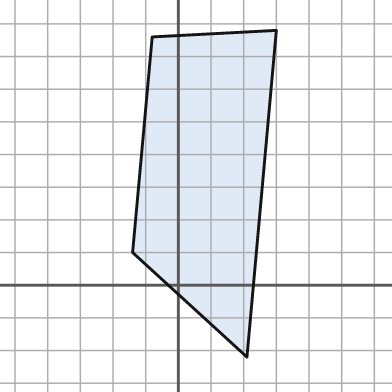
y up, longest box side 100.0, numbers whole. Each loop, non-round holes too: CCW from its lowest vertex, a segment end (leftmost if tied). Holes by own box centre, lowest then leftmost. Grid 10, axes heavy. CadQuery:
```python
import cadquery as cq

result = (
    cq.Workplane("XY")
    .moveTo(21.0, -22.0)
    .lineTo(30.0, 78.0)
    .lineTo(-8.0, 76.0)
    .lineTo(-14.0, 10.0)
    .close()
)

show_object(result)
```